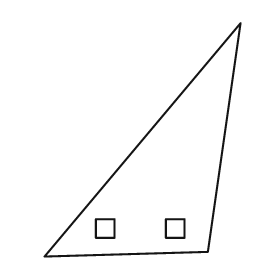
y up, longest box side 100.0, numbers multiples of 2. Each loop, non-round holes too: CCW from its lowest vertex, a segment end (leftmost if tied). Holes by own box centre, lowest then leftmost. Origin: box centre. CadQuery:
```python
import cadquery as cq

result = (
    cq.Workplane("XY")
    .moveTo(-42.0, -50.0)
    .lineTo(28.0, -48.0)
    .lineTo(42.0, 50.0)
    .close()
    .moveTo(-20.0, -42.0)
    .lineTo(-12.0, -42.0)
    .lineTo(-12.0, -34.0)
    .lineTo(-20.0, -34.0)
    .close()
    .moveTo(10.0, -42.0)
    .lineTo(18.0, -42.0)
    .lineTo(18.0, -34.0)
    .lineTo(10.0, -34.0)
    .close()
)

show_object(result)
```